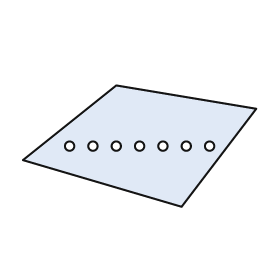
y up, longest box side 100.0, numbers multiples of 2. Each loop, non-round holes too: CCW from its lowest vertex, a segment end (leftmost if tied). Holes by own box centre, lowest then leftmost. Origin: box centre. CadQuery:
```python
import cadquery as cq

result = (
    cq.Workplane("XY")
    .moveTo(18.0, -26.0)
    .lineTo(50.0, 16.0)
    .lineTo(-10.0, 26.0)
    .lineTo(-50.0, -6.0)
    .close()
    .moveTo(-30.0, 0.0)
    .circle(2.0)
    .moveTo(-20.0, 0.0)
    .circle(2.0)
    .moveTo(-10.0, 0.0)
    .circle(2.0)
    .moveTo(0.0, 0.0)
    .circle(2.0)
    .moveTo(10.0, 0.0)
    .circle(2.0)
    .moveTo(20.0, 0.0)
    .circle(2.0)
    .moveTo(30.0, 0.0)
    .circle(2.0)
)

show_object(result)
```